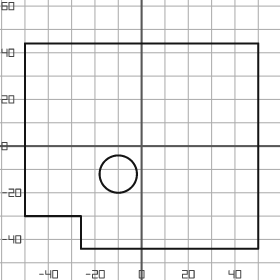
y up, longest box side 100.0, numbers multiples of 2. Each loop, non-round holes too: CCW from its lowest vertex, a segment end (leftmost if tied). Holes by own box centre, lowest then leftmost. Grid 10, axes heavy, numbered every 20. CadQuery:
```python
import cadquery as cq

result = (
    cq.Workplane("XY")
    .moveTo(-26.0, -44.0)
    .lineTo(50.0, -44.0)
    .lineTo(50.0, 44.0)
    .lineTo(-50.0, 44.0)
    .lineTo(-50.0, -30.0)
    .lineTo(-26.0, -30.0)
    .close()
    .moveTo(-10.0, -12.0)
    .circle(8.0)
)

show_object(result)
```